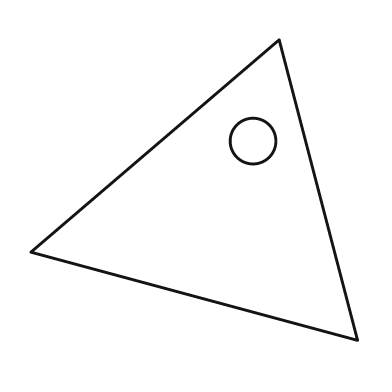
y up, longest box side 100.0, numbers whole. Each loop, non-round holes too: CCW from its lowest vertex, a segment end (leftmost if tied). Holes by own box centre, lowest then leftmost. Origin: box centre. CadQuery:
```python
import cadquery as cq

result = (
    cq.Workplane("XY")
    .moveTo(50.0, -46.0)
    .lineTo(26.0, 46.0)
    .lineTo(-50.0, -19.0)
    .close()
    .moveTo(18.0, 15.0)
    .circle(7.0)
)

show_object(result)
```